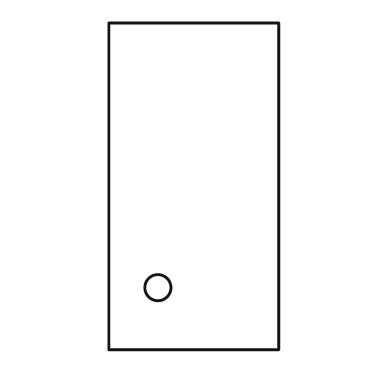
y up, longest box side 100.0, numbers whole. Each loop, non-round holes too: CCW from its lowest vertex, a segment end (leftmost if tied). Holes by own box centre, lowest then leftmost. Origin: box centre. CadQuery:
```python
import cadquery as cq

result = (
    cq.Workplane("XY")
    .moveTo(-26.0, -50.0)
    .lineTo(26.0, -50.0)
    .lineTo(26.0, 50.0)
    .lineTo(-26.0, 50.0)
    .close()
    .moveTo(-11.0, -31.0)
    .circle(4.0)
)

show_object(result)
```